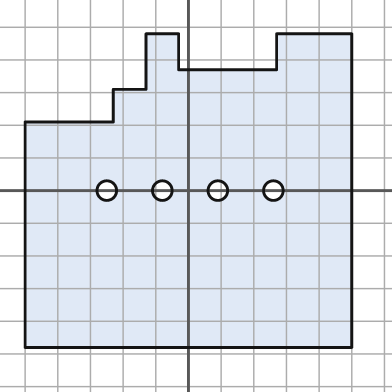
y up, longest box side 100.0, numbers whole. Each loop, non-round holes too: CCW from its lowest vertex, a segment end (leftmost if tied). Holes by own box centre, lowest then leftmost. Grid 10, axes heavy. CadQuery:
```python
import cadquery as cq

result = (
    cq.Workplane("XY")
    .moveTo(-50.0, -48.0)
    .lineTo(50.0, -48.0)
    .lineTo(50.0, 48.0)
    .lineTo(27.0, 48.0)
    .lineTo(27.0, 37.0)
    .lineTo(-3.0, 37.0)
    .lineTo(-3.0, 48.0)
    .lineTo(-13.0, 48.0)
    .lineTo(-13.0, 31.0)
    .lineTo(-23.0, 31.0)
    .lineTo(-23.0, 21.0)
    .lineTo(-50.0, 21.0)
    .close()
    .moveTo(-25.0, 0.0)
    .circle(3.0)
    .moveTo(-8.0, 0.0)
    .circle(3.0)
    .moveTo(9.0, 0.0)
    .circle(3.0)
    .moveTo(26.0, 0.0)
    .circle(3.0)
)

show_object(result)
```